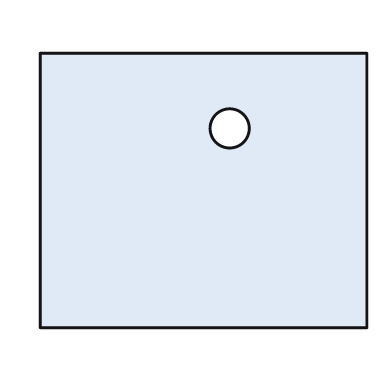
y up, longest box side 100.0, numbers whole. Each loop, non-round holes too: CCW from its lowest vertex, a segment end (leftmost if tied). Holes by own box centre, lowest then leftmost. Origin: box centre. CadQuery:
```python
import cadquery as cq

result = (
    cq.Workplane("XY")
    .moveTo(-50.0, -42.0)
    .lineTo(50.0, -42.0)
    .lineTo(50.0, 42.0)
    .lineTo(-50.0, 42.0)
    .close()
    .moveTo(8.0, 19.0)
    .circle(6.0)
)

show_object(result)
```